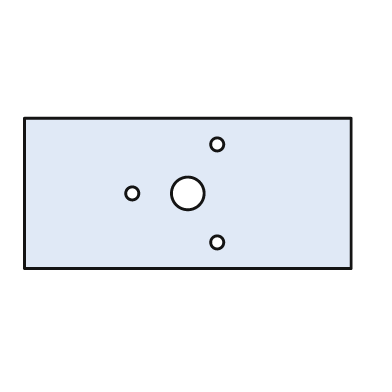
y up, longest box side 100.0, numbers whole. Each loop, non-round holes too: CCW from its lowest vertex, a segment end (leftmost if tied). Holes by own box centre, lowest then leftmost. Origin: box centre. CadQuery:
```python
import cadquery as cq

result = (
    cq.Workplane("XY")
    .moveTo(-50.0, -23.0)
    .lineTo(50.0, -23.0)
    .lineTo(50.0, 23.0)
    .lineTo(-50.0, 23.0)
    .close()
    .moveTo(9.0, -15.0)
    .circle(2.0)
    .moveTo(-17.0, 0.0)
    .circle(2.0)
    .moveTo(0.0, 0.0)
    .circle(5.0)
    .moveTo(9.0, 15.0)
    .circle(2.0)
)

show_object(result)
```